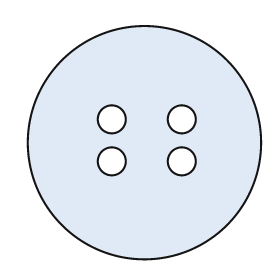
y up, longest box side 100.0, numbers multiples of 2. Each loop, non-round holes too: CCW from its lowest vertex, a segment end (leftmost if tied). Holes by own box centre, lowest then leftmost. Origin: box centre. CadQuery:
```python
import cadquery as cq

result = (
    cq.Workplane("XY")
    .moveTo(0.0, 0.0)
    .circle(50.0)
    .moveTo(-14.0, -8.0)
    .circle(6.0)
    .moveTo(16.0, -8.0)
    .circle(6.0)
    .moveTo(-14.0, 10.0)
    .circle(6.0)
    .moveTo(16.0, 10.0)
    .circle(6.0)
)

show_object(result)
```